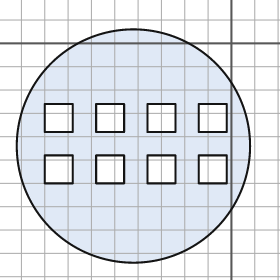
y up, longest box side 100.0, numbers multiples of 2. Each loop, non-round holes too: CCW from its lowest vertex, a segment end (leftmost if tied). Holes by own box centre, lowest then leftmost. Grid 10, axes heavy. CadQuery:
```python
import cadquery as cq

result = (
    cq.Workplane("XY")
    .moveTo(-42.0, -44.0)
    .circle(50.0)
    .moveTo(-80.0, -60.0)
    .lineTo(-68.0, -60.0)
    .lineTo(-68.0, -48.0)
    .lineTo(-80.0, -48.0)
    .close()
    .moveTo(-58.0, -60.0)
    .lineTo(-46.0, -60.0)
    .lineTo(-46.0, -48.0)
    .lineTo(-58.0, -48.0)
    .close()
    .moveTo(-36.0, -60.0)
    .lineTo(-24.0, -60.0)
    .lineTo(-24.0, -48.0)
    .lineTo(-36.0, -48.0)
    .close()
    .moveTo(-14.0, -60.0)
    .lineTo(-2.0, -60.0)
    .lineTo(-2.0, -48.0)
    .lineTo(-14.0, -48.0)
    .close()
    .moveTo(-80.0, -38.0)
    .lineTo(-68.0, -38.0)
    .lineTo(-68.0, -26.0)
    .lineTo(-80.0, -26.0)
    .close()
    .moveTo(-58.0, -38.0)
    .lineTo(-46.0, -38.0)
    .lineTo(-46.0, -26.0)
    .lineTo(-58.0, -26.0)
    .close()
    .moveTo(-36.0, -38.0)
    .lineTo(-24.0, -38.0)
    .lineTo(-24.0, -26.0)
    .lineTo(-36.0, -26.0)
    .close()
    .moveTo(-14.0, -38.0)
    .lineTo(-2.0, -38.0)
    .lineTo(-2.0, -26.0)
    .lineTo(-14.0, -26.0)
    .close()
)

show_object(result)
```